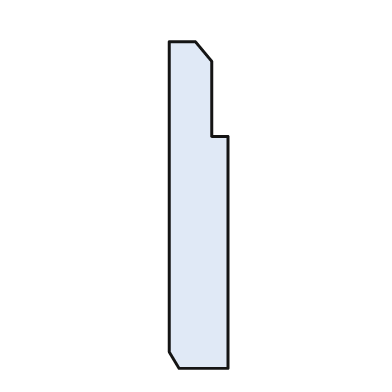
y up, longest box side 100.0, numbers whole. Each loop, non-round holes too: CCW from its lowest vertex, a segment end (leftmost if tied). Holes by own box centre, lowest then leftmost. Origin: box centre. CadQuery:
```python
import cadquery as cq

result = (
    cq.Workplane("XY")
    .moveTo(-6.0, -50.0)
    .lineTo(9.0, -50.0)
    .lineTo(9.0, 21.0)
    .lineTo(4.0, 21.0)
    .lineTo(4.0, 44.0)
    .lineTo(-1.0, 50.0)
    .lineTo(-9.0, 50.0)
    .lineTo(-9.0, -45.0)
    .close()
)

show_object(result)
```